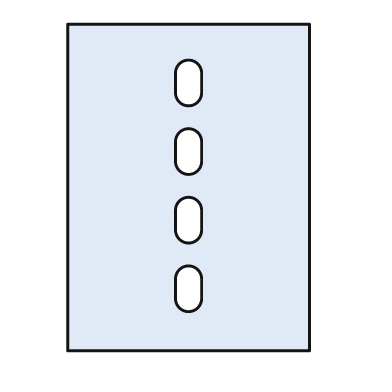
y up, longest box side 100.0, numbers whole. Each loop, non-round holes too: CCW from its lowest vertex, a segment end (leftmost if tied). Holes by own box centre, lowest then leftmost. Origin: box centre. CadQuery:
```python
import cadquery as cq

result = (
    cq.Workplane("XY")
    .moveTo(-37.0, -50.0)
    .lineTo(37.0, -50.0)
    .lineTo(37.0, 50.0)
    .lineTo(-37.0, 50.0)
    .close()
    .moveTo(-4.0, -34.0)
    .threePointArc((0.0, -38.0), (4.0, -34.0))
    .lineTo(4.0, -28.0)
    .threePointArc((0.0, -24.0), (-4.0, -28.0))
    .close()
    .moveTo(-4.0, -13.0)
    .threePointArc((0.0, -17.0), (4.0, -13.0))
    .lineTo(4.0, -7.0)
    .threePointArc((0.0, -3.0), (-4.0, -7.0))
    .close()
    .moveTo(-4.0, 8.0)
    .threePointArc((0.0, 4.0), (4.0, 8.0))
    .lineTo(4.0, 14.0)
    .threePointArc((0.0, 18.0), (-4.0, 14.0))
    .close()
    .moveTo(-4.0, 29.0)
    .threePointArc((0.0, 25.0), (4.0, 29.0))
    .lineTo(4.0, 35.0)
    .threePointArc((0.0, 39.0), (-4.0, 35.0))
    .close()
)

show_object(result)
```